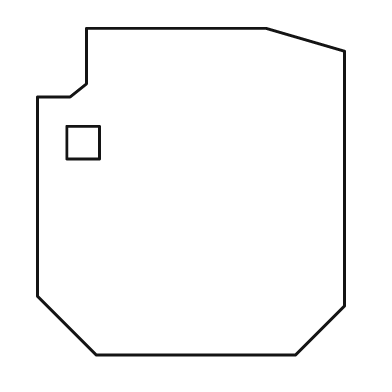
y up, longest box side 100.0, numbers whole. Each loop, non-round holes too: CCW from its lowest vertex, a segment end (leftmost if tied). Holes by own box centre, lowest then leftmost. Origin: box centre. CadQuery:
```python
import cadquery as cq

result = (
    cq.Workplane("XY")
    .moveTo(-29.0, -50.0)
    .lineTo(32.0, -50.0)
    .lineTo(47.0, -35.0)
    .lineTo(47.0, 43.0)
    .lineTo(23.0, 50.0)
    .lineTo(-32.0, 50.0)
    .lineTo(-32.0, 33.0)
    .lineTo(-37.0, 29.0)
    .lineTo(-47.0, 29.0)
    .lineTo(-47.0, -32.0)
    .close()
    .moveTo(-38.0, 10.0)
    .lineTo(-28.0, 10.0)
    .lineTo(-28.0, 20.0)
    .lineTo(-38.0, 20.0)
    .close()
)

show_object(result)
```